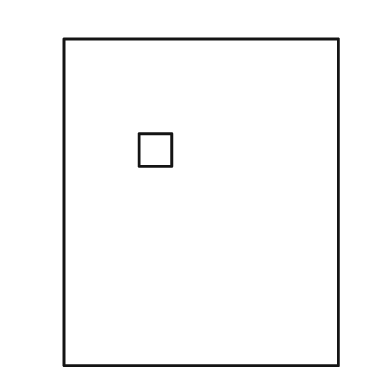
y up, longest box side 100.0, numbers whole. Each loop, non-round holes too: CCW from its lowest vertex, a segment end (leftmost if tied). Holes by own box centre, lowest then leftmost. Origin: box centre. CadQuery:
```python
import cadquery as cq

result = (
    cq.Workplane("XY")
    .moveTo(-42.0, -50.0)
    .lineTo(42.0, -50.0)
    .lineTo(42.0, 50.0)
    .lineTo(-42.0, 50.0)
    .close()
    .moveTo(-19.0, 11.0)
    .lineTo(-9.0, 11.0)
    .lineTo(-9.0, 21.0)
    .lineTo(-19.0, 21.0)
    .close()
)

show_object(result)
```